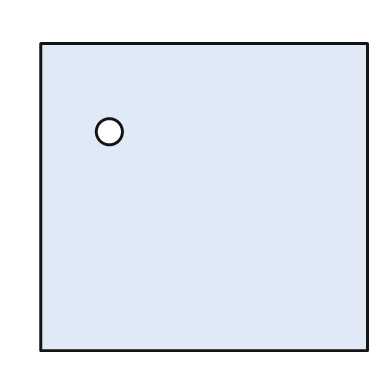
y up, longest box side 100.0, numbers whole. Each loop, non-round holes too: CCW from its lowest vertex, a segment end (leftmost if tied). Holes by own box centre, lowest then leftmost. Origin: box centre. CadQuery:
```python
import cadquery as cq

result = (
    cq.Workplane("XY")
    .moveTo(-50.0, -47.0)
    .lineTo(50.0, -47.0)
    .lineTo(50.0, 47.0)
    .lineTo(-50.0, 47.0)
    .close()
    .moveTo(-29.0, 20.0)
    .circle(4.0)
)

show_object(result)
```